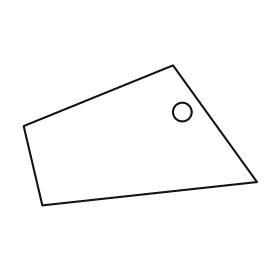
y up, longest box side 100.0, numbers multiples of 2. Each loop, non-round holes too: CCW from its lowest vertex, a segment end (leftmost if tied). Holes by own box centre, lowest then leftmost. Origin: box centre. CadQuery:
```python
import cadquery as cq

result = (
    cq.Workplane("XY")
    .moveTo(-42.0, -30.0)
    .lineTo(50.0, -20.0)
    .lineTo(14.0, 30.0)
    .lineTo(-50.0, 4.0)
    .close()
    .moveTo(18.0, 10.0)
    .circle(4.0)
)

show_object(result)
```